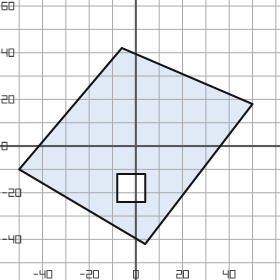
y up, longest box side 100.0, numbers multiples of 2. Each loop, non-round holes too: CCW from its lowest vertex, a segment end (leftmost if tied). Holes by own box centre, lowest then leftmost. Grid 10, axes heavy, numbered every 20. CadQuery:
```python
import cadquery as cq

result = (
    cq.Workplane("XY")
    .moveTo(4.0, -42.0)
    .lineTo(50.0, 18.0)
    .lineTo(-6.0, 42.0)
    .lineTo(-50.0, -10.0)
    .close()
    .moveTo(-8.0, -24.0)
    .lineTo(4.0, -24.0)
    .lineTo(4.0, -12.0)
    .lineTo(-8.0, -12.0)
    .close()
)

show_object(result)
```